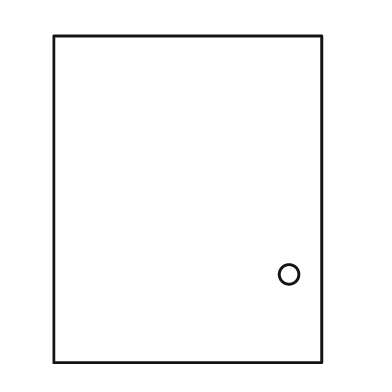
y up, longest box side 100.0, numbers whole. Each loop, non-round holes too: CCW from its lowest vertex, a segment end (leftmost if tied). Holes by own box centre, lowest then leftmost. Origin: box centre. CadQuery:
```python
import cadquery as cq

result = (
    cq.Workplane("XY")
    .moveTo(-41.0, -50.0)
    .lineTo(41.0, -50.0)
    .lineTo(41.0, 50.0)
    .lineTo(-41.0, 50.0)
    .close()
    .moveTo(31.0, -23.0)
    .circle(3.0)
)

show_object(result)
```